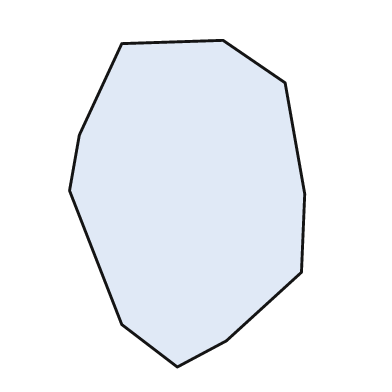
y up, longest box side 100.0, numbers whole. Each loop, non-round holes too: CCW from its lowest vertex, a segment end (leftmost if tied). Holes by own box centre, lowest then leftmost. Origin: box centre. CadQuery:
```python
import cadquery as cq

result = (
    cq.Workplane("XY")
    .moveTo(-3.0, -50.0)
    .lineTo(12.0, -42.0)
    .lineTo(35.0, -21.0)
    .lineTo(36.0, 3.0)
    .lineTo(30.0, 37.0)
    .lineTo(11.0, 50.0)
    .lineTo(-20.0, 49.0)
    .lineTo(-33.0, 21.0)
    .lineTo(-36.0, 4.0)
    .lineTo(-20.0, -37.0)
    .close()
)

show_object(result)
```